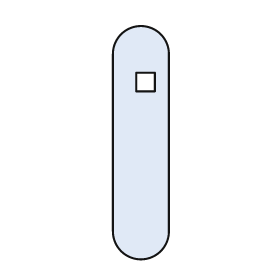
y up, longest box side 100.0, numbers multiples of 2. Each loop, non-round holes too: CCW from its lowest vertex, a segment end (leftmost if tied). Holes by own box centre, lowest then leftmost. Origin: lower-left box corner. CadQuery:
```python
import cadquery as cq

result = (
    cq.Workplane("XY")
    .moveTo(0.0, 12.0)
    .threePointArc((12.0, 0.0), (24.0, 12.0))
    .lineTo(24.0, 88.0)
    .threePointArc((12.0, 100.0), (0.0, 88.0))
    .close()
    .moveTo(10.0, 72.0)
    .lineTo(18.0, 72.0)
    .lineTo(18.0, 80.0)
    .lineTo(10.0, 80.0)
    .close()
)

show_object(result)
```